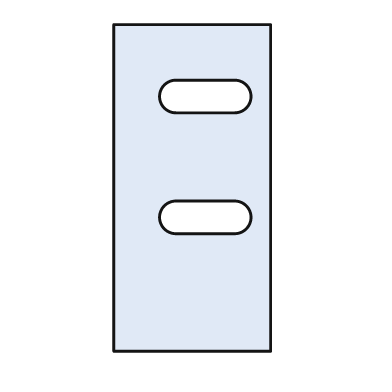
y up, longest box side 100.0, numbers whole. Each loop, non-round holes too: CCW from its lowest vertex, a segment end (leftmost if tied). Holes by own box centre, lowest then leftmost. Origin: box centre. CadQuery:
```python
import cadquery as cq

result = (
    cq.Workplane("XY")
    .moveTo(-24.0, -50.0)
    .lineTo(24.0, -50.0)
    .lineTo(24.0, 50.0)
    .lineTo(-24.0, 50.0)
    .close()
    .moveTo(-5.0, -14.0)
    .lineTo(13.0, -14.0)
    .threePointArc((18.0, -9.0), (13.0, -4.0))
    .lineTo(-5.0, -4.0)
    .threePointArc((-10.0, -9.0), (-5.0, -14.0))
    .close()
    .moveTo(-5.0, 23.0)
    .lineTo(13.0, 23.0)
    .threePointArc((18.0, 28.0), (13.0, 33.0))
    .lineTo(-5.0, 33.0)
    .threePointArc((-10.0, 28.0), (-5.0, 23.0))
    .close()
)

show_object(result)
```